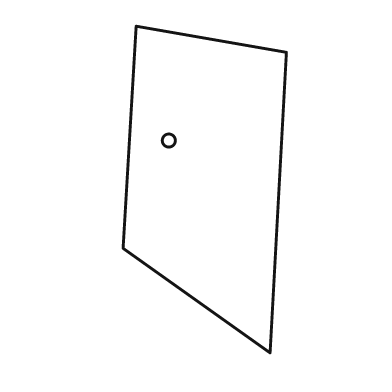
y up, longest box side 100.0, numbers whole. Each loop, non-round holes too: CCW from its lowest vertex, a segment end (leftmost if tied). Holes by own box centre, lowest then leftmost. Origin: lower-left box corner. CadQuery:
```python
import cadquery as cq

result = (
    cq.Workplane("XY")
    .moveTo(45.0, 0.0)
    .lineTo(50.0, 92.0)
    .lineTo(4.0, 100.0)
    .lineTo(0.0, 32.0)
    .close()
    .moveTo(14.0, 65.0)
    .circle(2.0)
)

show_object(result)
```